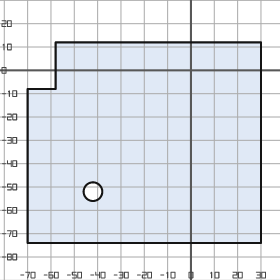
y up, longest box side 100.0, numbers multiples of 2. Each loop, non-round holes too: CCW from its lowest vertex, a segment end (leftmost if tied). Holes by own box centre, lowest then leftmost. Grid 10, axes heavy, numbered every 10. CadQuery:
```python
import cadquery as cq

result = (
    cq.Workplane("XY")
    .moveTo(-70.0, -74.0)
    .lineTo(30.0, -74.0)
    .lineTo(30.0, 12.0)
    .lineTo(-58.0, 12.0)
    .lineTo(-58.0, -8.0)
    .lineTo(-70.0, -8.0)
    .close()
    .moveTo(-42.0, -52.0)
    .circle(4.0)
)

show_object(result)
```